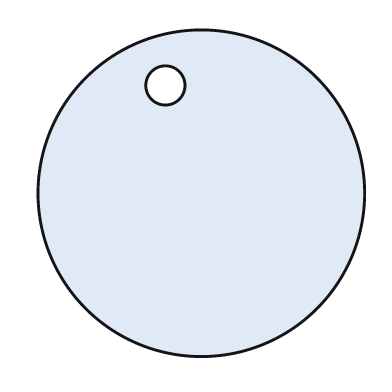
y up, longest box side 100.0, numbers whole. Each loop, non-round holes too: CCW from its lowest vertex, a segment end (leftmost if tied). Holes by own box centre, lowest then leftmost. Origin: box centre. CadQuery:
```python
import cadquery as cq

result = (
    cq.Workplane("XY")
    .moveTo(0.0, 0.0)
    .circle(50.0)
    .moveTo(-11.0, 33.0)
    .circle(6.0)
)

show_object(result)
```